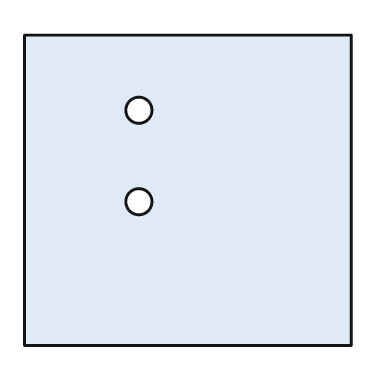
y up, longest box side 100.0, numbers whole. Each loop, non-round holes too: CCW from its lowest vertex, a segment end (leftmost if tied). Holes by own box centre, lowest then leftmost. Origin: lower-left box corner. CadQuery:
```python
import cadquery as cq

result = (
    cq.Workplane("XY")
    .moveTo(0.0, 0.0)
    .lineTo(100.0, 0.0)
    .lineTo(100.0, 95.0)
    .lineTo(0.0, 95.0)
    .close()
    .moveTo(35.0, 44.0)
    .circle(4.0)
    .moveTo(35.0, 72.0)
    .circle(4.0)
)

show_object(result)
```